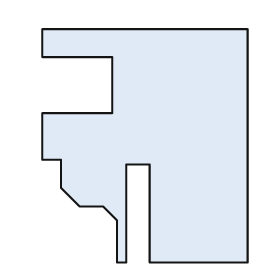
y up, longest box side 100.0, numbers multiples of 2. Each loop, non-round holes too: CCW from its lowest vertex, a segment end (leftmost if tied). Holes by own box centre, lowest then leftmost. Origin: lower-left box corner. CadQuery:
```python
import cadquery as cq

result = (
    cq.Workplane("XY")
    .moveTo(32.0, 0.0)
    .lineTo(36.0, 0.0)
    .lineTo(36.0, 42.0)
    .lineTo(46.0, 42.0)
    .lineTo(46.0, 0.0)
    .lineTo(88.0, 0.0)
    .lineTo(88.0, 100.0)
    .lineTo(0.0, 100.0)
    .lineTo(0.0, 88.0)
    .lineTo(30.0, 88.0)
    .lineTo(30.0, 64.0)
    .lineTo(0.0, 64.0)
    .lineTo(0.0, 44.0)
    .lineTo(8.0, 44.0)
    .lineTo(8.0, 32.0)
    .lineTo(16.0, 24.0)
    .lineTo(26.0, 24.0)
    .lineTo(32.0, 18.0)
    .close()
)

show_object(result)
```